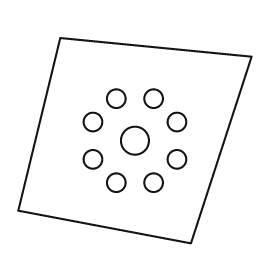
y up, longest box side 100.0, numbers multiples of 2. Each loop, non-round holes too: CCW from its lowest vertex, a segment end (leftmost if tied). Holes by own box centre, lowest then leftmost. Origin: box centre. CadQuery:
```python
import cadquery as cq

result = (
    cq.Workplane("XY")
    .moveTo(24.0, -44.0)
    .lineTo(50.0, 36.0)
    .lineTo(-32.0, 44.0)
    .lineTo(-50.0, -30.0)
    .close()
    .moveTo(-8.0, -18.0)
    .circle(4.0)
    .moveTo(8.0, -18.0)
    .circle(4.0)
    .moveTo(-18.0, -8.0)
    .circle(4.0)
    .moveTo(18.0, -8.0)
    .circle(4.0)
    .moveTo(0.0, 0.0)
    .circle(6.0)
    .moveTo(-18.0, 8.0)
    .circle(4.0)
    .moveTo(18.0, 8.0)
    .circle(4.0)
    .moveTo(-8.0, 18.0)
    .circle(4.0)
    .moveTo(8.0, 18.0)
    .circle(4.0)
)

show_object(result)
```